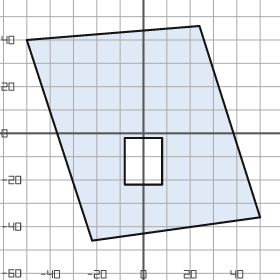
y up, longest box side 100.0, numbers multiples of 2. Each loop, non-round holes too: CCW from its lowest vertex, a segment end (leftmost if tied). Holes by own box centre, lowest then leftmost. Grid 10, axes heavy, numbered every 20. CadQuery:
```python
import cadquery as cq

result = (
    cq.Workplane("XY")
    .moveTo(-22.0, -46.0)
    .lineTo(50.0, -36.0)
    .lineTo(24.0, 46.0)
    .lineTo(-50.0, 40.0)
    .close()
    .moveTo(-8.0, -22.0)
    .lineTo(8.0, -22.0)
    .lineTo(8.0, -2.0)
    .lineTo(-8.0, -2.0)
    .close()
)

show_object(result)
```